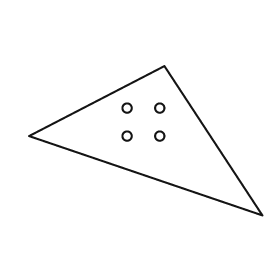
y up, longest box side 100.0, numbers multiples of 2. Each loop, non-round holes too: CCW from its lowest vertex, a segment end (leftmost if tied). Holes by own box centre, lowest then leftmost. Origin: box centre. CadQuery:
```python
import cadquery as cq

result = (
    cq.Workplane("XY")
    .moveTo(50.0, -32.0)
    .lineTo(8.0, 32.0)
    .lineTo(-50.0, 2.0)
    .close()
    .moveTo(-8.0, 2.0)
    .circle(2.0)
    .moveTo(6.0, 2.0)
    .circle(2.0)
    .moveTo(-8.0, 14.0)
    .circle(2.0)
    .moveTo(6.0, 14.0)
    .circle(2.0)
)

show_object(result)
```